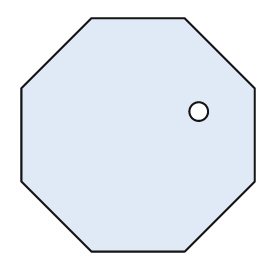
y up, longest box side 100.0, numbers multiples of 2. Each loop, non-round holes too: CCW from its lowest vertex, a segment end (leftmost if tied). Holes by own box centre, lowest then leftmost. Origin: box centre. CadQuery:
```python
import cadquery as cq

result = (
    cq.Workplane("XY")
    .moveTo(-20.0, -50.0)
    .lineTo(20.0, -50.0)
    .lineTo(50.0, -20.0)
    .lineTo(50.0, 20.0)
    .lineTo(20.0, 50.0)
    .lineTo(-20.0, 50.0)
    .lineTo(-50.0, 20.0)
    .lineTo(-50.0, -20.0)
    .close()
    .moveTo(26.0, 10.0)
    .circle(4.0)
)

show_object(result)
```